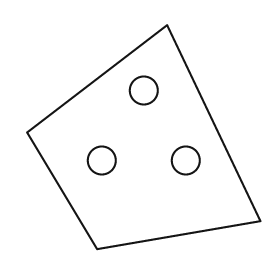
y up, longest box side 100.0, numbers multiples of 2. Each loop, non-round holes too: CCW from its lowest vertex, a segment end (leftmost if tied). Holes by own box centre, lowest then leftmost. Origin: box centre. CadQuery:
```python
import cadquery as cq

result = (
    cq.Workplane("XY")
    .moveTo(-20.0, -48.0)
    .lineTo(50.0, -36.0)
    .lineTo(10.0, 48.0)
    .lineTo(-50.0, 2.0)
    .close()
    .moveTo(-18.0, -10.0)
    .circle(6.0)
    .moveTo(18.0, -10.0)
    .circle(6.0)
    .moveTo(0.0, 20.0)
    .circle(6.0)
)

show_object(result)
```